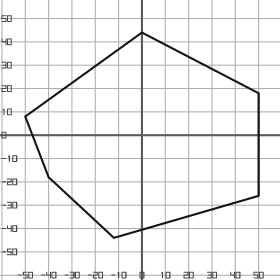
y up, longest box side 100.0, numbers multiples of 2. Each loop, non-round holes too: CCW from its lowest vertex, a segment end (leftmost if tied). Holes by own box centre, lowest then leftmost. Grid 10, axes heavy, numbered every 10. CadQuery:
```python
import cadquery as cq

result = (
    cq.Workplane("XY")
    .moveTo(-12.0, -44.0)
    .lineTo(50.0, -26.0)
    .lineTo(50.0, 18.0)
    .lineTo(0.0, 44.0)
    .lineTo(-50.0, 8.0)
    .lineTo(-40.0, -18.0)
    .close()
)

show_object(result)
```